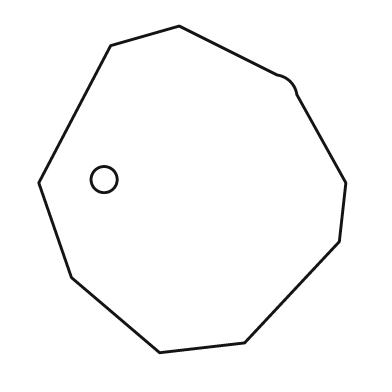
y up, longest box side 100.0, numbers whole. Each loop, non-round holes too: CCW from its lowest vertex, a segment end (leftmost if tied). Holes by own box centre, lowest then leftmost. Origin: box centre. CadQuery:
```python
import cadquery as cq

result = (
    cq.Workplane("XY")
    .moveTo(-10.0, -50.0)
    .lineTo(16.0, -47.0)
    .lineTo(45.0, -16.0)
    .lineTo(47.0, 2.0)
    .lineTo(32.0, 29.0)
    .threePointArc((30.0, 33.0), (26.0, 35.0))
    .lineTo(-4.0, 50.0)
    .lineTo(-25.0, 44.0)
    .lineTo(-47.0, 2.0)
    .lineTo(-37.0, -27.0)
    .close()
    .moveTo(-27.0, 3.0)
    .circle(4.0)
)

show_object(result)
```